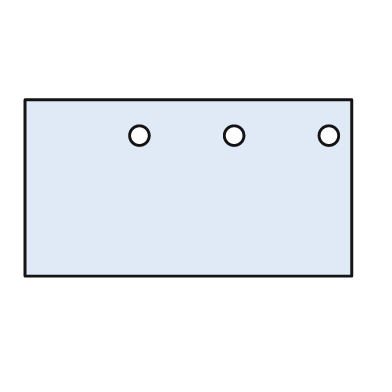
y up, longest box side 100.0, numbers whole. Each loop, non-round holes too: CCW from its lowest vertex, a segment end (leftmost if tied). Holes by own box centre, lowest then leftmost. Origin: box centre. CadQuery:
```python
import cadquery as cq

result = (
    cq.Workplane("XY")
    .moveTo(-50.0, -27.0)
    .lineTo(50.0, -27.0)
    .lineTo(50.0, 27.0)
    .lineTo(-50.0, 27.0)
    .close()
    .moveTo(-15.0, 16.0)
    .circle(3.0)
    .moveTo(14.0, 16.0)
    .circle(3.0)
    .moveTo(43.0, 16.0)
    .circle(3.0)
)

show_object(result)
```